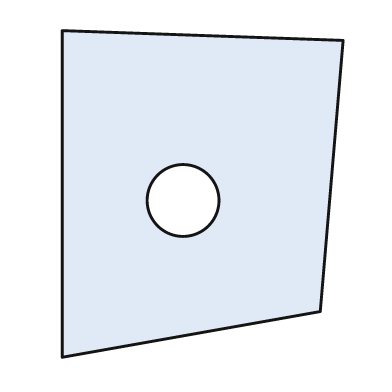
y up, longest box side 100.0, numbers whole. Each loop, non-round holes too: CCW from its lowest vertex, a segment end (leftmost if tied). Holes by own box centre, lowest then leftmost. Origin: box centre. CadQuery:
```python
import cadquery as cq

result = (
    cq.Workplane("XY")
    .moveTo(-43.0, -50.0)
    .lineTo(36.0, -36.0)
    .lineTo(43.0, 47.0)
    .lineTo(-43.0, 50.0)
    .close()
    .moveTo(-6.0, -2.0)
    .circle(11.0)
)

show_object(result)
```